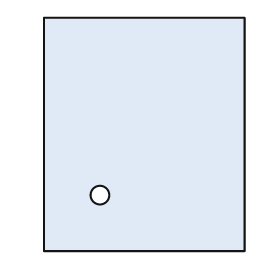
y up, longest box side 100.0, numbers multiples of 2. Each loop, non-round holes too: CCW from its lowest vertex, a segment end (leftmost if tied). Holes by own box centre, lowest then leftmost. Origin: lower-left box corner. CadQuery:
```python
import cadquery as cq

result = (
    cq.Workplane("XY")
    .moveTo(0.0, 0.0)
    .lineTo(86.0, 0.0)
    .lineTo(86.0, 100.0)
    .lineTo(0.0, 100.0)
    .close()
    .moveTo(24.0, 24.0)
    .circle(4.0)
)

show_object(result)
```